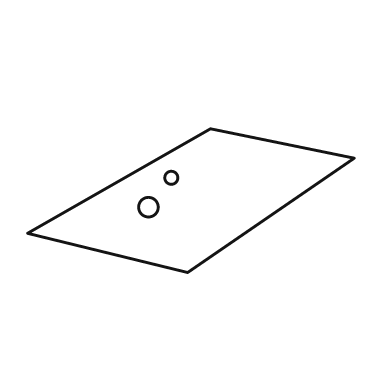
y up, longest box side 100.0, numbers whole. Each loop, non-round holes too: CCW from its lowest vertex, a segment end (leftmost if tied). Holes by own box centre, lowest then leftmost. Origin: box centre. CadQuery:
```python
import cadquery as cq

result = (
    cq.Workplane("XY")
    .moveTo(-1.0, -22.0)
    .lineTo(50.0, 13.0)
    .lineTo(6.0, 22.0)
    .lineTo(-50.0, -10.0)
    .close()
    .moveTo(-13.0, -2.0)
    .circle(3.0)
    .moveTo(-6.0, 7.0)
    .circle(2.0)
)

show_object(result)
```